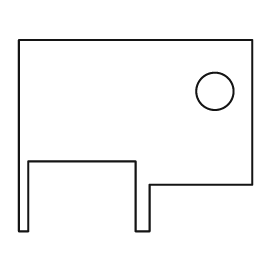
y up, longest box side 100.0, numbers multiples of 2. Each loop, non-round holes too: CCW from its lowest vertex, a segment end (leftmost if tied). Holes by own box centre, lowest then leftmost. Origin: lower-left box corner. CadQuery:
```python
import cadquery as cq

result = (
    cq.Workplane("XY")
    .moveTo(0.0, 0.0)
    .lineTo(4.0, 0.0)
    .lineTo(4.0, 30.0)
    .lineTo(50.0, 30.0)
    .lineTo(50.0, 0.0)
    .lineTo(56.0, 0.0)
    .lineTo(56.0, 20.0)
    .lineTo(100.0, 20.0)
    .lineTo(100.0, 82.0)
    .lineTo(0.0, 82.0)
    .close()
    .moveTo(84.0, 60.0)
    .circle(8.0)
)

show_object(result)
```